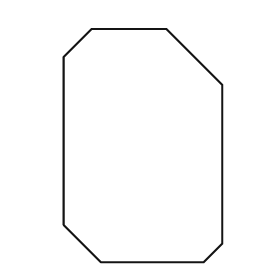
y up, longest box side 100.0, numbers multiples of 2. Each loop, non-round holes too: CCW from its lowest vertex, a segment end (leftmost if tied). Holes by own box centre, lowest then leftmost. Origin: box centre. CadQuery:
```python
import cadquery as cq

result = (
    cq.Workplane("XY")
    .moveTo(-18.0, -50.0)
    .lineTo(26.0, -50.0)
    .lineTo(34.0, -42.0)
    .lineTo(34.0, 26.0)
    .lineTo(10.0, 50.0)
    .lineTo(-22.0, 50.0)
    .lineTo(-34.0, 38.0)
    .lineTo(-34.0, -34.0)
    .close()
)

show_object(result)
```